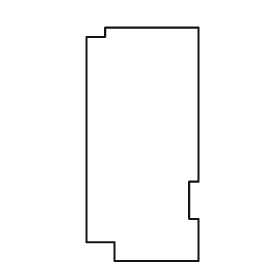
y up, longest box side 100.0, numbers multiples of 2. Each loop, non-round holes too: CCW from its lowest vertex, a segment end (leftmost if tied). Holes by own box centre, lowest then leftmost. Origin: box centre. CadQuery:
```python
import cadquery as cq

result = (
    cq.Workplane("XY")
    .moveTo(-12.0, -50.0)
    .lineTo(24.0, -50.0)
    .lineTo(24.0, -32.0)
    .lineTo(20.0, -32.0)
    .lineTo(20.0, -16.0)
    .lineTo(24.0, -16.0)
    .lineTo(24.0, 50.0)
    .lineTo(-16.0, 50.0)
    .lineTo(-16.0, 46.0)
    .lineTo(-24.0, 46.0)
    .lineTo(-24.0, -42.0)
    .lineTo(-12.0, -42.0)
    .close()
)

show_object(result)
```